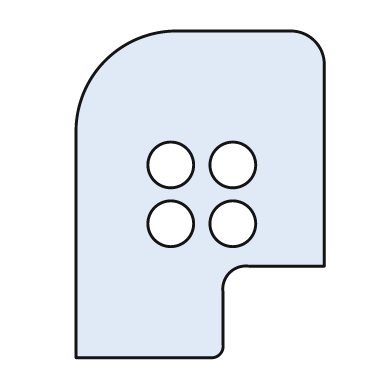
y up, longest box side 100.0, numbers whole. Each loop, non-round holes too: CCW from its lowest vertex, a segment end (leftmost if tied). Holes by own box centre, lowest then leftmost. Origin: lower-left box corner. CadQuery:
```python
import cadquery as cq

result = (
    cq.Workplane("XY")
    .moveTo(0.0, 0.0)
    .lineTo(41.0, 0.0)
    .threePointArc((44.0, 1.0), (45.0, 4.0))
    .lineTo(45.0, 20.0)
    .threePointArc((47.0, 26.0), (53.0, 28.0))
    .lineTo(76.0, 28.0)
    .lineTo(76.0, 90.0)
    .threePointArc((73.0, 97.0), (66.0, 100.0))
    .lineTo(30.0, 100.0)
    .threePointArc((9.0, 91.0), (0.0, 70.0))
    .close()
    .moveTo(29.0, 41.0)
    .circle(7.0)
    .moveTo(48.0, 41.0)
    .circle(7.0)
    .moveTo(29.0, 59.0)
    .circle(7.0)
    .moveTo(48.0, 59.0)
    .circle(7.0)
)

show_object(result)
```